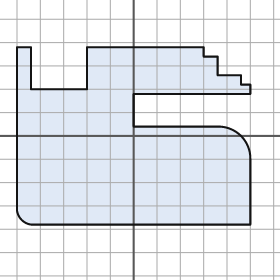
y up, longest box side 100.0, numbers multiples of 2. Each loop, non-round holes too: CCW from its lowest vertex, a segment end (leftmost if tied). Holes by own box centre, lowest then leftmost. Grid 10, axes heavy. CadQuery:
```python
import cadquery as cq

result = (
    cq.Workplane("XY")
    .moveTo(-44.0, -38.0)
    .lineTo(50.0, -38.0)
    .lineTo(50.0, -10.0)
    .threePointArc((46.0, 0.0), (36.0, 4.0))
    .lineTo(0.0, 4.0)
    .lineTo(0.0, 18.0)
    .lineTo(50.0, 18.0)
    .lineTo(50.0, 22.0)
    .lineTo(46.0, 22.0)
    .lineTo(46.0, 26.0)
    .lineTo(36.0, 26.0)
    .lineTo(36.0, 34.0)
    .lineTo(30.0, 34.0)
    .lineTo(30.0, 38.0)
    .lineTo(-20.0, 38.0)
    .lineTo(-20.0, 20.0)
    .lineTo(-44.0, 20.0)
    .lineTo(-44.0, 38.0)
    .lineTo(-50.0, 38.0)
    .lineTo(-50.0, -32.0)
    .threePointArc((-48.0, -36.0), (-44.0, -38.0))
    .close()
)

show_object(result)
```